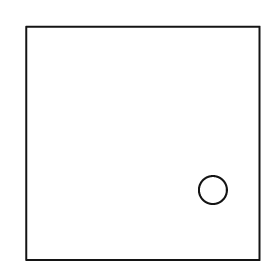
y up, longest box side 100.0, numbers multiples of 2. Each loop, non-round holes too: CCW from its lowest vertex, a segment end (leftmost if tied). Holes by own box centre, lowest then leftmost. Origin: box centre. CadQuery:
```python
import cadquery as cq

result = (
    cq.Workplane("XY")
    .moveTo(-50.0, -50.0)
    .lineTo(50.0, -50.0)
    .lineTo(50.0, 50.0)
    .lineTo(-50.0, 50.0)
    .close()
    .moveTo(30.0, -20.0)
    .circle(6.0)
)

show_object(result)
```